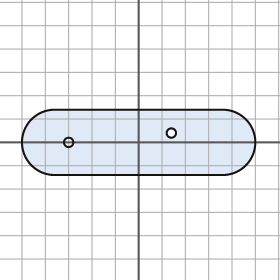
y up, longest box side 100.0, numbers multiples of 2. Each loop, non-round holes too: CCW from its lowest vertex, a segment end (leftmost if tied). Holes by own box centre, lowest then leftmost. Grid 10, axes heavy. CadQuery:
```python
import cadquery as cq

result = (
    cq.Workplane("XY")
    .moveTo(-36.0, -14.0)
    .lineTo(36.0, -14.0)
    .threePointArc((50.0, 0.0), (36.0, 14.0))
    .lineTo(-36.0, 14.0)
    .threePointArc((-50.0, 0.0), (-36.0, -14.0))
    .close()
    .moveTo(-30.0, 0.0)
    .circle(2.0)
    .moveTo(14.0, 4.0)
    .circle(2.0)
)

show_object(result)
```